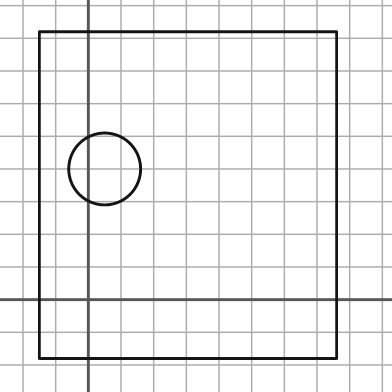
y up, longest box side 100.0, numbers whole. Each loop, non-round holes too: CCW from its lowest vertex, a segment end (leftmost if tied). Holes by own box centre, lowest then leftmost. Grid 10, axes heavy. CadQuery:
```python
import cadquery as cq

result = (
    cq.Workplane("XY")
    .moveTo(-15.0, -18.0)
    .lineTo(76.0, -18.0)
    .lineTo(76.0, 82.0)
    .lineTo(-15.0, 82.0)
    .close()
    .moveTo(5.0, 40.0)
    .circle(11.0)
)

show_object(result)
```